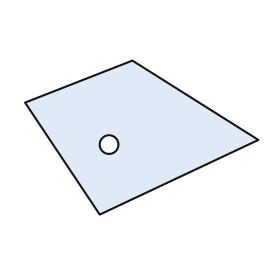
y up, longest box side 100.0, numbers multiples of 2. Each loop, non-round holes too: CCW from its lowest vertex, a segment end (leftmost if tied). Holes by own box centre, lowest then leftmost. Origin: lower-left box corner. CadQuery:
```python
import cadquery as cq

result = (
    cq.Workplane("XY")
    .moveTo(32.0, 0.0)
    .lineTo(100.0, 32.0)
    .lineTo(46.0, 66.0)
    .lineTo(0.0, 48.0)
    .close()
    .moveTo(36.0, 30.0)
    .circle(4.0)
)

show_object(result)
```